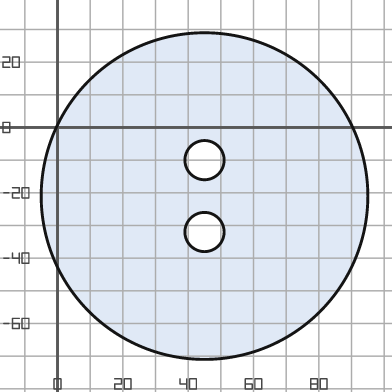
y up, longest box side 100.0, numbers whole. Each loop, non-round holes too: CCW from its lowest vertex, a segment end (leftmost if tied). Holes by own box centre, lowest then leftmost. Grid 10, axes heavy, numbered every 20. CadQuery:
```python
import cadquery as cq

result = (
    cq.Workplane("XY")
    .moveTo(45.0, -21.0)
    .circle(50.0)
    .moveTo(45.0, -32.0)
    .circle(6.0)
    .moveTo(45.0, -10.0)
    .circle(6.0)
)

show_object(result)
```